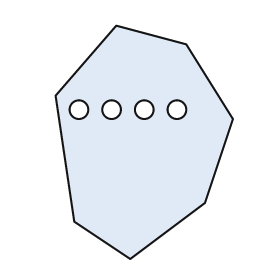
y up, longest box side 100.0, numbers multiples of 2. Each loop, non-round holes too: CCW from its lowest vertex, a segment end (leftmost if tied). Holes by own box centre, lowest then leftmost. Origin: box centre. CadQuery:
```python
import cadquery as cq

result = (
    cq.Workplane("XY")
    .moveTo(-6.0, -50.0)
    .lineTo(26.0, -26.0)
    .lineTo(38.0, 10.0)
    .lineTo(18.0, 42.0)
    .lineTo(-12.0, 50.0)
    .lineTo(-38.0, 20.0)
    .lineTo(-30.0, -34.0)
    .close()
    .moveTo(-28.0, 14.0)
    .circle(4.0)
    .moveTo(-14.0, 14.0)
    .circle(4.0)
    .moveTo(0.0, 14.0)
    .circle(4.0)
    .moveTo(14.0, 14.0)
    .circle(4.0)
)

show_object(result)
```